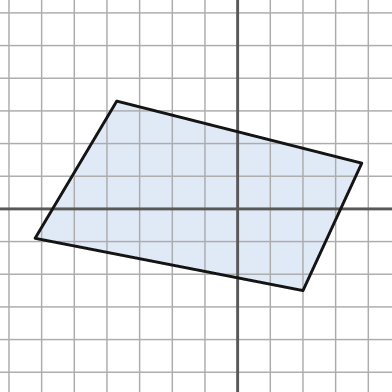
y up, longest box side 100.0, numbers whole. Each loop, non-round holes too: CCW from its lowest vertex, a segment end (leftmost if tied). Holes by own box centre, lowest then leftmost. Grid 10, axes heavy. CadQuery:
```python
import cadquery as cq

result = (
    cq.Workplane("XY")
    .moveTo(20.0, -25.0)
    .lineTo(38.0, 14.0)
    .lineTo(-37.0, 33.0)
    .lineTo(-62.0, -9.0)
    .close()
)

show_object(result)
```